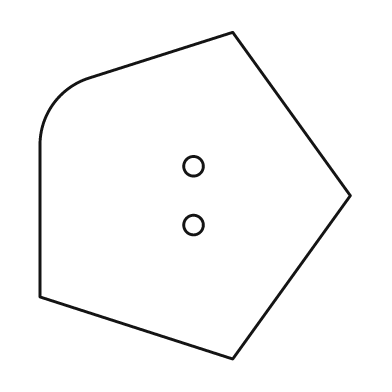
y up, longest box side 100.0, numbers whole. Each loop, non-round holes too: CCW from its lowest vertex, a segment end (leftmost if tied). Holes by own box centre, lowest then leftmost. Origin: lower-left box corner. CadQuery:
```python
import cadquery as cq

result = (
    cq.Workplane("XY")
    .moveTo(59.0, 0.0)
    .lineTo(95.0, 50.0)
    .lineTo(59.0, 100.0)
    .lineTo(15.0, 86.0)
    .threePointArc((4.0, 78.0), (0.0, 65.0))
    .lineTo(0.0, 19.0)
    .close()
    .moveTo(47.0, 41.0)
    .circle(3.0)
    .moveTo(47.0, 59.0)
    .circle(3.0)
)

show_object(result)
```